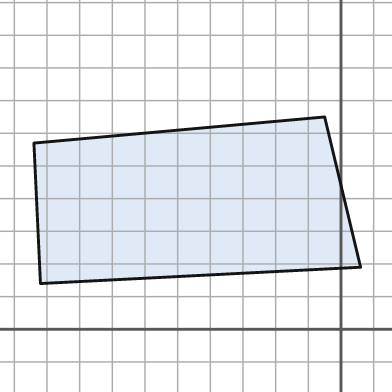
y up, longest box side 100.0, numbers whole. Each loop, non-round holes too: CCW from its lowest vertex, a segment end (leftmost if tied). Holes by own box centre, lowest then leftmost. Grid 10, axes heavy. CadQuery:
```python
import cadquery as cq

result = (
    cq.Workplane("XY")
    .moveTo(-92.0, 14.0)
    .lineTo(6.0, 19.0)
    .lineTo(-5.0, 65.0)
    .lineTo(-94.0, 57.0)
    .close()
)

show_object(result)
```